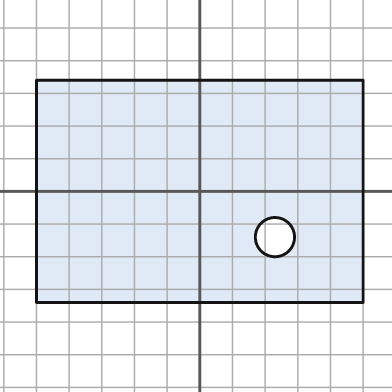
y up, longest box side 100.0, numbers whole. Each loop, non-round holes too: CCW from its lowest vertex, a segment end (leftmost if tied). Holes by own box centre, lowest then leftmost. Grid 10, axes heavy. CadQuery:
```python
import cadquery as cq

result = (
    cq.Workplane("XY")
    .moveTo(-50.0, -34.0)
    .lineTo(50.0, -34.0)
    .lineTo(50.0, 34.0)
    .lineTo(-50.0, 34.0)
    .close()
    .moveTo(23.0, -14.0)
    .circle(6.0)
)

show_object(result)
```